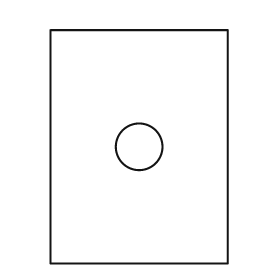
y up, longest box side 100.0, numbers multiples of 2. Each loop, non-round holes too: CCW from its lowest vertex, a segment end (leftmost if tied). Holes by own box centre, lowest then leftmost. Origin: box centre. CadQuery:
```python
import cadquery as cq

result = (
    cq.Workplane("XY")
    .moveTo(-38.0, -50.0)
    .lineTo(38.0, -50.0)
    .lineTo(38.0, 50.0)
    .lineTo(-38.0, 50.0)
    .close()
    .moveTo(0.0, 0.0)
    .circle(10.0)
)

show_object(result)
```